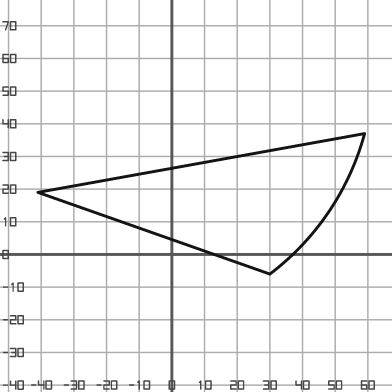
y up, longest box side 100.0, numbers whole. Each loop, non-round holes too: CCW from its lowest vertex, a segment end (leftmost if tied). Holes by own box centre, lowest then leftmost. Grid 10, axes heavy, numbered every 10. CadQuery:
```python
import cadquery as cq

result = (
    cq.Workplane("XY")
    .moveTo(30.0, -6.0)
    .threePointArc((48.0, 13.0), (59.0, 37.0))
    .lineTo(-41.0, 19.0)
    .close()
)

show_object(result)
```